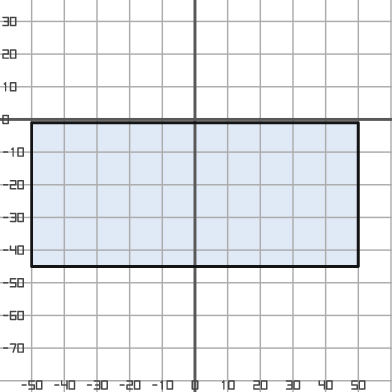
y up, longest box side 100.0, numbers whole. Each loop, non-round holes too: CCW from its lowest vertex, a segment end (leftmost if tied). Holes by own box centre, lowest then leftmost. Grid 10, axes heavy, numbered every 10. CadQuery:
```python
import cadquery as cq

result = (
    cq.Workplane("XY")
    .moveTo(-50.0, -45.0)
    .lineTo(50.0, -45.0)
    .lineTo(50.0, -1.0)
    .lineTo(-50.0, -1.0)
    .close()
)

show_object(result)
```